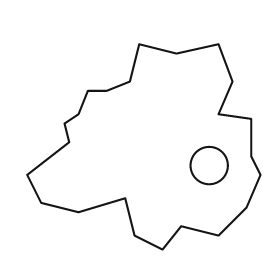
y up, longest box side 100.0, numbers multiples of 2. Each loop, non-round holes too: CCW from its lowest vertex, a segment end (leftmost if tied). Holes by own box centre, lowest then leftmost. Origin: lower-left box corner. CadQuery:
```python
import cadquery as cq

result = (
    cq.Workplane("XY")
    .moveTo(58.0, 0.0)
    .lineTo(66.0, 10.0)
    .lineTo(82.0, 6.0)
    .lineTo(94.0, 18.0)
    .lineTo(100.0, 32.0)
    .lineTo(96.0, 40.0)
    .lineTo(96.0, 56.0)
    .lineTo(82.0, 58.0)
    .lineTo(88.0, 72.0)
    .lineTo(82.0, 88.0)
    .lineTo(64.0, 84.0)
    .lineTo(48.0, 88.0)
    .lineTo(44.0, 72.0)
    .lineTo(34.0, 68.0)
    .lineTo(26.0, 68.0)
    .lineTo(22.0, 58.0)
    .lineTo(16.0, 54.0)
    .lineTo(18.0, 46.0)
    .lineTo(0.0, 32.0)
    .lineTo(6.0, 20.0)
    .lineTo(22.0, 16.0)
    .lineTo(42.0, 22.0)
    .lineTo(46.0, 6.0)
    .close()
    .moveTo(78.0, 36.0)
    .circle(8.0)
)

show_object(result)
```